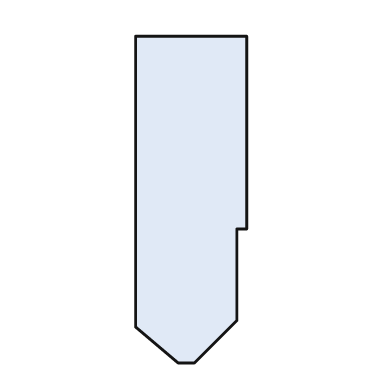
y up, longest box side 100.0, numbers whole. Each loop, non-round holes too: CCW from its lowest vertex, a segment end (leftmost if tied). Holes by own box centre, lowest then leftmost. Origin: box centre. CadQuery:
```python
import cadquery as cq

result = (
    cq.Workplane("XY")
    .moveTo(-4.0, -50.0)
    .lineTo(1.0, -50.0)
    .lineTo(14.0, -37.0)
    .lineTo(14.0, -9.0)
    .lineTo(17.0, -9.0)
    .lineTo(17.0, 50.0)
    .lineTo(-17.0, 50.0)
    .lineTo(-17.0, -39.0)
    .close()
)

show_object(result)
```